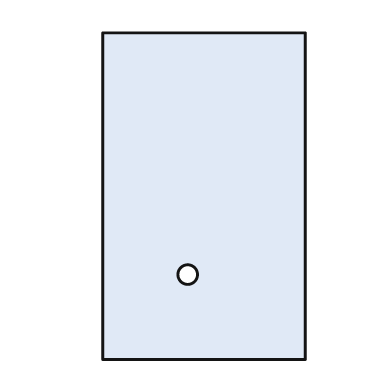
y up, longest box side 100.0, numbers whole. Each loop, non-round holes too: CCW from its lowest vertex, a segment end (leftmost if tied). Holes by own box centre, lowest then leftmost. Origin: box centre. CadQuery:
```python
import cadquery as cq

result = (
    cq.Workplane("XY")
    .moveTo(-31.0, -50.0)
    .lineTo(31.0, -50.0)
    .lineTo(31.0, 50.0)
    .lineTo(-31.0, 50.0)
    .close()
    .moveTo(-5.0, -24.0)
    .circle(3.0)
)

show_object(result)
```